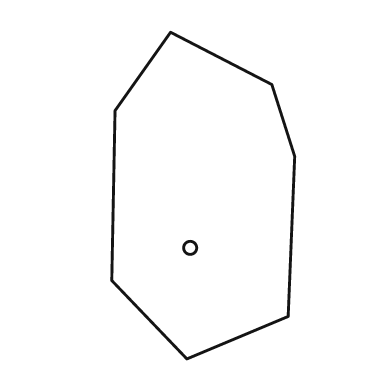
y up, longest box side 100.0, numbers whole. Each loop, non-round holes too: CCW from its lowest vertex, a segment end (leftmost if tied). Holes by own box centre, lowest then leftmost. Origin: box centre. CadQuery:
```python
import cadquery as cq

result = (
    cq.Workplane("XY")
    .moveTo(-5.0, -50.0)
    .lineTo(26.0, -37.0)
    .lineTo(28.0, 12.0)
    .lineTo(21.0, 34.0)
    .lineTo(-10.0, 50.0)
    .lineTo(-27.0, 26.0)
    .lineTo(-28.0, -26.0)
    .close()
    .moveTo(-4.0, -16.0)
    .circle(2.0)
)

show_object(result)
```